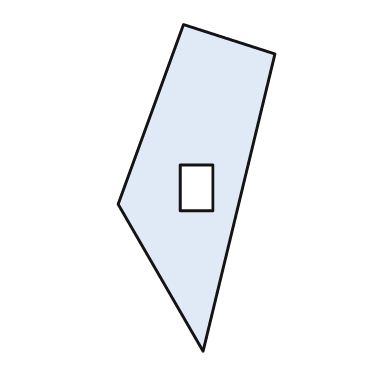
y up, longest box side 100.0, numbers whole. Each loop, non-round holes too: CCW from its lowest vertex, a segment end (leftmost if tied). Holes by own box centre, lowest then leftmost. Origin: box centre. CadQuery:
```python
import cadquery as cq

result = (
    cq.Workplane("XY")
    .moveTo(2.0, -50.0)
    .lineTo(24.0, 41.0)
    .lineTo(-4.0, 50.0)
    .lineTo(-24.0, -5.0)
    .close()
    .moveTo(-5.0, -7.0)
    .lineTo(5.0, -7.0)
    .lineTo(5.0, 7.0)
    .lineTo(-5.0, 7.0)
    .close()
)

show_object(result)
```